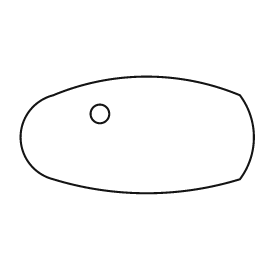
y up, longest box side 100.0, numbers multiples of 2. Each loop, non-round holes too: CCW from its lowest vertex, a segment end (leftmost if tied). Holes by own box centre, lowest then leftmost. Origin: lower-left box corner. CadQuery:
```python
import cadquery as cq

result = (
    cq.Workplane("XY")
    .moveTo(14.0, 6.0)
    .threePointArc((54.0, 0.0), (94.0, 6.0))
    .threePointArc((100.0, 24.0), (94.0, 42.0))
    .threePointArc((54.0, 50.0), (14.0, 42.0))
    .threePointArc((0.0, 24.0), (14.0, 6.0))
    .close()
    .moveTo(34.0, 34.0)
    .circle(4.0)
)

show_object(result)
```